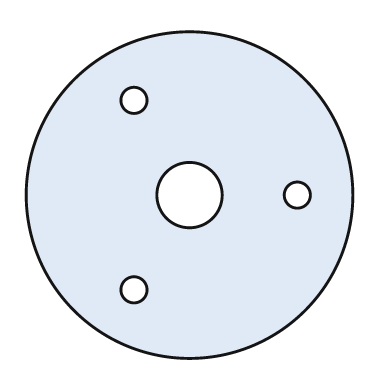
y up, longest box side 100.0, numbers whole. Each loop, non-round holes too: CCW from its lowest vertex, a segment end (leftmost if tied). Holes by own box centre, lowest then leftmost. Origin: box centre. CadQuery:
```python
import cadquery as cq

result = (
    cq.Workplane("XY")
    .moveTo(0.0, 0.0)
    .circle(50.0)
    .moveTo(-17.0, -29.0)
    .circle(4.0)
    .moveTo(0.0, 0.0)
    .circle(10.0)
    .moveTo(33.0, 0.0)
    .circle(4.0)
    .moveTo(-17.0, 29.0)
    .circle(4.0)
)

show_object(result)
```